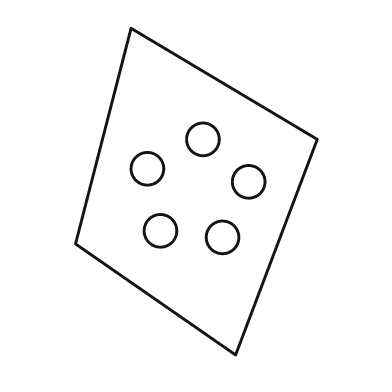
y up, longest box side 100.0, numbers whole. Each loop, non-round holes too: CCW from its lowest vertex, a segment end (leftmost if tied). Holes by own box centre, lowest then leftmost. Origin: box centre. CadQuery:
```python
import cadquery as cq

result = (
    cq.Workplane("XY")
    .moveTo(12.0, -50.0)
    .lineTo(37.0, 16.0)
    .lineTo(-20.0, 50.0)
    .lineTo(-37.0, -16.0)
    .close()
    .moveTo(8.0, -14.0)
    .circle(5.0)
    .moveTo(-11.0, -12.0)
    .circle(5.0)
    .moveTo(16.0, 3.0)
    .circle(5.0)
    .moveTo(-15.0, 7.0)
    .circle(5.0)
    .moveTo(2.0, 16.0)
    .circle(5.0)
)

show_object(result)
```